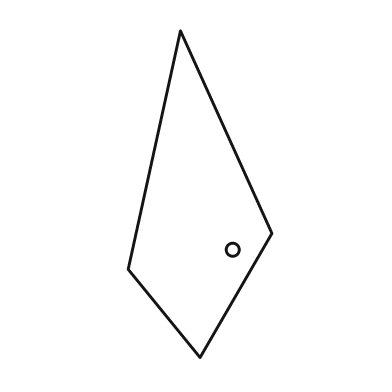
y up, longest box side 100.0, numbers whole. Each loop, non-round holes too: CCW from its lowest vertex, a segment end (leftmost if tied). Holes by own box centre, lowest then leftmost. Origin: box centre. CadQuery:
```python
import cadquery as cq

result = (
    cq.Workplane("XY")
    .moveTo(0.0, -50.0)
    .lineTo(22.0, -12.0)
    .lineTo(-6.0, 50.0)
    .lineTo(-22.0, -23.0)
    .close()
    .moveTo(10.0, -17.0)
    .circle(2.0)
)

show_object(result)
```